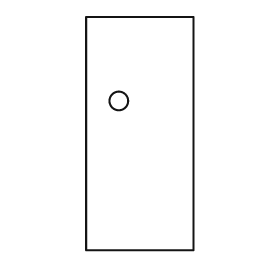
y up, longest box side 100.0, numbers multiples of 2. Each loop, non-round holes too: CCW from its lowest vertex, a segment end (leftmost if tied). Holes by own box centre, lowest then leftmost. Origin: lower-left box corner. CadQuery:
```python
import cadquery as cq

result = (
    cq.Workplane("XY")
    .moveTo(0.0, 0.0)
    .lineTo(46.0, 0.0)
    .lineTo(46.0, 100.0)
    .lineTo(0.0, 100.0)
    .close()
    .moveTo(14.0, 64.0)
    .circle(4.0)
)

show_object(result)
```